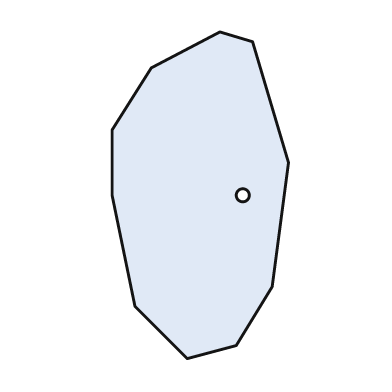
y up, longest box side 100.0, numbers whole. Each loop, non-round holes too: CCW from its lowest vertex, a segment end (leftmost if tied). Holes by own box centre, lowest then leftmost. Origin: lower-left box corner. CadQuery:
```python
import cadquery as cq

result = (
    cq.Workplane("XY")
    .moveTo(23.0, 0.0)
    .lineTo(38.0, 4.0)
    .lineTo(49.0, 22.0)
    .lineTo(54.0, 60.0)
    .lineTo(43.0, 97.0)
    .lineTo(33.0, 100.0)
    .lineTo(12.0, 89.0)
    .lineTo(0.0, 70.0)
    .lineTo(0.0, 50.0)
    .lineTo(7.0, 16.0)
    .close()
    .moveTo(40.0, 50.0)
    .circle(2.0)
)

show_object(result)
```